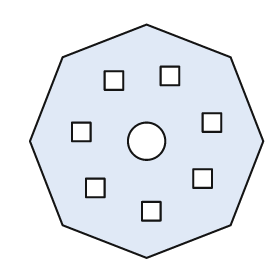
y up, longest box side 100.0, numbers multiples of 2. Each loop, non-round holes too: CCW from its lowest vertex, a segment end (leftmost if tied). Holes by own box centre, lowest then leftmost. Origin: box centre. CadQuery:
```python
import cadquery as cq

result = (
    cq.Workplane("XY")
    .moveTo(0.0, -50.0)
    .lineTo(36.0, -36.0)
    .lineTo(50.0, 0.0)
    .lineTo(36.0, 36.0)
    .lineTo(0.0, 50.0)
    .lineTo(-36.0, 36.0)
    .lineTo(-50.0, 0.0)
    .lineTo(-36.0, -36.0)
    .close()
    .moveTo(-2.0, -34.0)
    .lineTo(6.0, -34.0)
    .lineTo(6.0, -26.0)
    .lineTo(-2.0, -26.0)
    .close()
    .moveTo(-26.0, -24.0)
    .lineTo(-18.0, -24.0)
    .lineTo(-18.0, -16.0)
    .lineTo(-26.0, -16.0)
    .close()
    .moveTo(20.0, -20.0)
    .lineTo(28.0, -20.0)
    .lineTo(28.0, -12.0)
    .lineTo(20.0, -12.0)
    .close()
    .moveTo(0.0, 0.0)
    .circle(8.0)
    .moveTo(-32.0, 0.0)
    .lineTo(-24.0, 0.0)
    .lineTo(-24.0, 8.0)
    .lineTo(-32.0, 8.0)
    .close()
    .moveTo(24.0, 4.0)
    .lineTo(32.0, 4.0)
    .lineTo(32.0, 12.0)
    .lineTo(24.0, 12.0)
    .close()
    .moveTo(-18.0, 22.0)
    .lineTo(-10.0, 22.0)
    .lineTo(-10.0, 30.0)
    .lineTo(-18.0, 30.0)
    .close()
    .moveTo(6.0, 24.0)
    .lineTo(14.0, 24.0)
    .lineTo(14.0, 32.0)
    .lineTo(6.0, 32.0)
    .close()
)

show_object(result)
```